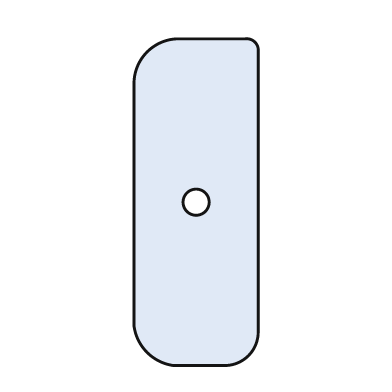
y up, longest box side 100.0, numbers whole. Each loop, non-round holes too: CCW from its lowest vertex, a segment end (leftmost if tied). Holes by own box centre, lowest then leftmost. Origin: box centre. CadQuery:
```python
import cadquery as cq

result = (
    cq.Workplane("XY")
    .moveTo(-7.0, -50.0)
    .lineTo(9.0, -50.0)
    .threePointArc((16.0, -47.0), (19.0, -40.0))
    .lineTo(19.0, 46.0)
    .threePointArc((18.0, 49.0), (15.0, 50.0))
    .lineTo(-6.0, 50.0)
    .threePointArc((-15.0, 46.0), (-19.0, 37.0))
    .lineTo(-19.0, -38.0)
    .threePointArc((-15.0, -46.0), (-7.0, -50.0))
    .close()
    .moveTo(0.0, 0.0)
    .circle(4.0)
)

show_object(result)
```